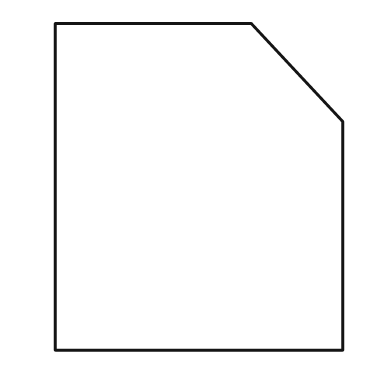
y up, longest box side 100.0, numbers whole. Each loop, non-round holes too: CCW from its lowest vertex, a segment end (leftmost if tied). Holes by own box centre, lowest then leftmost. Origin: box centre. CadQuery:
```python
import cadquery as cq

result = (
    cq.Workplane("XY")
    .moveTo(-44.0, -50.0)
    .lineTo(44.0, -50.0)
    .lineTo(44.0, 20.0)
    .lineTo(16.0, 50.0)
    .lineTo(-44.0, 50.0)
    .close()
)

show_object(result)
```